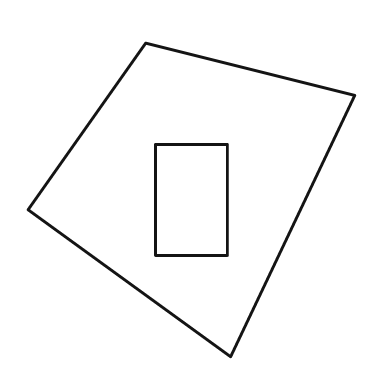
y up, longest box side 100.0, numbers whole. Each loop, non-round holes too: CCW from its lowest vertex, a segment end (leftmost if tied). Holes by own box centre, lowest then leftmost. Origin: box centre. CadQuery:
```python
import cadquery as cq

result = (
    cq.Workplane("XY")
    .moveTo(12.0, -48.0)
    .lineTo(50.0, 32.0)
    .lineTo(-14.0, 48.0)
    .lineTo(-50.0, -3.0)
    .close()
    .moveTo(-11.0, -17.0)
    .lineTo(11.0, -17.0)
    .lineTo(11.0, 17.0)
    .lineTo(-11.0, 17.0)
    .close()
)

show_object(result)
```